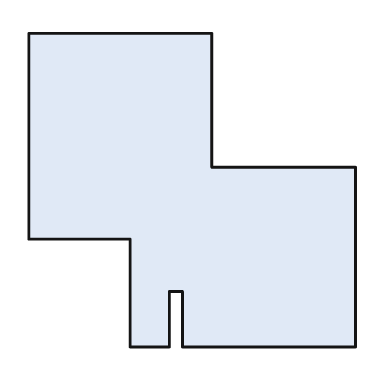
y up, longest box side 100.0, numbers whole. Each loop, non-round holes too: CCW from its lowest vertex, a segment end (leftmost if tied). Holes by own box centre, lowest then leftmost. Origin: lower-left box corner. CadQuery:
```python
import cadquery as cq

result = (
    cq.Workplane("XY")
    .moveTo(31.0, 0.0)
    .lineTo(43.0, 0.0)
    .lineTo(43.0, 17.0)
    .lineTo(47.0, 17.0)
    .lineTo(47.0, 0.0)
    .lineTo(100.0, 0.0)
    .lineTo(100.0, 55.0)
    .lineTo(56.0, 55.0)
    .lineTo(56.0, 96.0)
    .lineTo(0.0, 96.0)
    .lineTo(0.0, 33.0)
    .lineTo(31.0, 33.0)
    .close()
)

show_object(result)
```